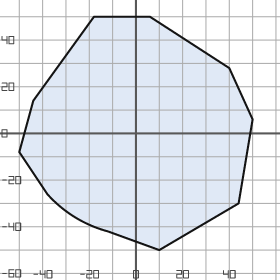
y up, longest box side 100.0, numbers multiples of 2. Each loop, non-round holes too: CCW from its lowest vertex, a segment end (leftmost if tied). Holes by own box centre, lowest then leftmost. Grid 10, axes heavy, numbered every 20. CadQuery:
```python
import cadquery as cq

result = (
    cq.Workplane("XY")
    .moveTo(10.0, -50.0)
    .lineTo(44.0, -30.0)
    .lineTo(50.0, 6.0)
    .lineTo(40.0, 28.0)
    .lineTo(6.0, 50.0)
    .lineTo(-18.0, 50.0)
    .lineTo(-44.0, 14.0)
    .lineTo(-50.0, -8.0)
    .lineTo(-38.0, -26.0)
    .threePointArc((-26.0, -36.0), (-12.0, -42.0))
    .close()
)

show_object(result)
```